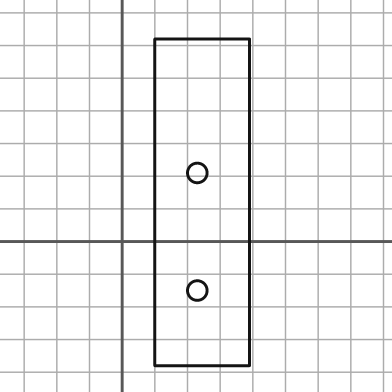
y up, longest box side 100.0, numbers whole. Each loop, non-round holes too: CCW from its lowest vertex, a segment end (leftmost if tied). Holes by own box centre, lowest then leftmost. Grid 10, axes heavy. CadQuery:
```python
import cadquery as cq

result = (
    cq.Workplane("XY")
    .moveTo(10.0, -38.0)
    .lineTo(39.0, -38.0)
    .lineTo(39.0, 62.0)
    .lineTo(10.0, 62.0)
    .close()
    .moveTo(23.0, -15.0)
    .circle(3.0)
    .moveTo(23.0, 21.0)
    .circle(3.0)
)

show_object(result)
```